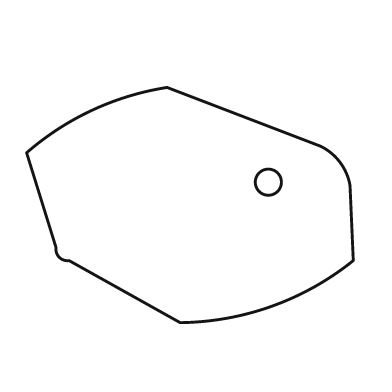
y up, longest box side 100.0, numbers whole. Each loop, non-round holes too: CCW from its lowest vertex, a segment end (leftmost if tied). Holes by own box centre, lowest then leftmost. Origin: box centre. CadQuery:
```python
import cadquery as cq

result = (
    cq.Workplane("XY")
    .moveTo(-3.0, -36.0)
    .threePointArc((25.0, -31.0), (50.0, -17.0))
    .lineTo(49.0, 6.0)
    .threePointArc((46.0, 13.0), (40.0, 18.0))
    .lineTo(-7.0, 36.0)
    .threePointArc((-30.0, 29.0), (-50.0, 16.0))
    .lineTo(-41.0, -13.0)
    .threePointArc((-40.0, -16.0), (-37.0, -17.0))
    .close()
    .moveTo(24.0, 7.0)
    .circle(4.0)
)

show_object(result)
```